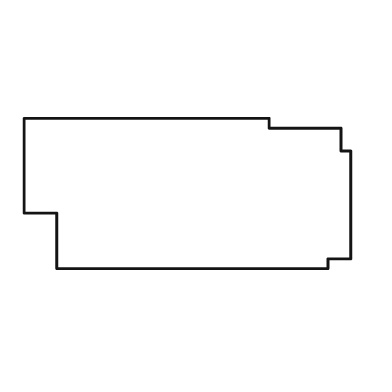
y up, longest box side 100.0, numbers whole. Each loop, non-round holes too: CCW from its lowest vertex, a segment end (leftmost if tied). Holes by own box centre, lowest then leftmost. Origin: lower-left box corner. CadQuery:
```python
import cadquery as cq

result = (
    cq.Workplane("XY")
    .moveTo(10.0, 0.0)
    .lineTo(93.0, 0.0)
    .lineTo(93.0, 3.0)
    .lineTo(100.0, 3.0)
    .lineTo(100.0, 36.0)
    .lineTo(97.0, 36.0)
    .lineTo(97.0, 43.0)
    .lineTo(75.0, 43.0)
    .lineTo(75.0, 46.0)
    .lineTo(0.0, 46.0)
    .lineTo(0.0, 17.0)
    .lineTo(10.0, 17.0)
    .close()
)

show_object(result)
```